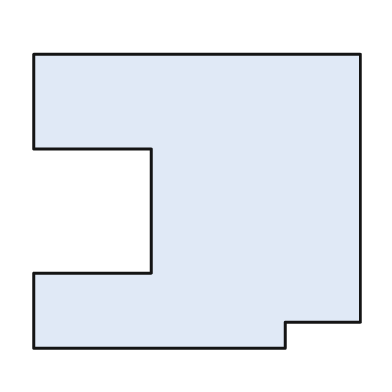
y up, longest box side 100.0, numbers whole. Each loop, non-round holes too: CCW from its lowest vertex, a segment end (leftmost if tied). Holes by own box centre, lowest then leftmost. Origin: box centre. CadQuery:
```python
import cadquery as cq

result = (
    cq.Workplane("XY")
    .moveTo(-50.0, -45.0)
    .lineTo(27.0, -45.0)
    .lineTo(27.0, -37.0)
    .lineTo(50.0, -37.0)
    .lineTo(50.0, 45.0)
    .lineTo(-50.0, 45.0)
    .lineTo(-50.0, 16.0)
    .lineTo(-14.0, 16.0)
    .lineTo(-14.0, -22.0)
    .lineTo(-50.0, -22.0)
    .close()
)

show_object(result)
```